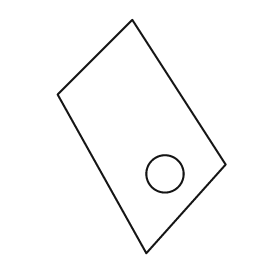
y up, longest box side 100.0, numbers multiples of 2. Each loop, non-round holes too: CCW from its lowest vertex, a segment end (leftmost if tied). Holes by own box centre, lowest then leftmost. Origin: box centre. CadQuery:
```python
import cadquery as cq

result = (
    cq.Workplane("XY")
    .moveTo(2.0, -50.0)
    .lineTo(36.0, -12.0)
    .lineTo(-4.0, 50.0)
    .lineTo(-36.0, 18.0)
    .close()
    .moveTo(10.0, -16.0)
    .circle(8.0)
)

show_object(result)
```